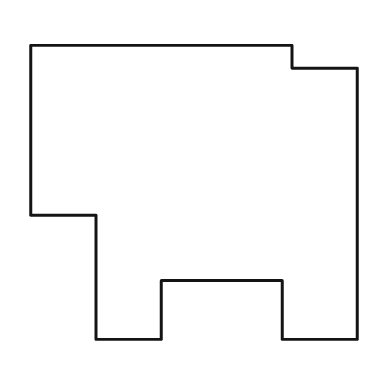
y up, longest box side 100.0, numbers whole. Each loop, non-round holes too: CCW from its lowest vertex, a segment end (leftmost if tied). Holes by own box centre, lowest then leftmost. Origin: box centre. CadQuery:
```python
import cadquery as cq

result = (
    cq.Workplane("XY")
    .moveTo(-30.0, -45.0)
    .lineTo(-10.0, -45.0)
    .lineTo(-10.0, -27.0)
    .lineTo(27.0, -27.0)
    .lineTo(27.0, -45.0)
    .lineTo(50.0, -45.0)
    .lineTo(50.0, 38.0)
    .lineTo(30.0, 38.0)
    .lineTo(30.0, 45.0)
    .lineTo(-50.0, 45.0)
    .lineTo(-50.0, -7.0)
    .lineTo(-30.0, -7.0)
    .close()
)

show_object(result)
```